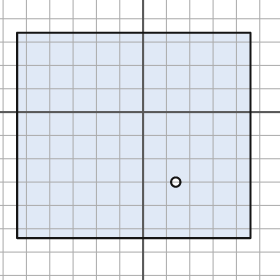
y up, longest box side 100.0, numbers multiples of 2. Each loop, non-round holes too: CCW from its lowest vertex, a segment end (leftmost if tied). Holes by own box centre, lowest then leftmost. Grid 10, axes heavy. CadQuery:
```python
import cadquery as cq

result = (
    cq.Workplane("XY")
    .moveTo(-54.0, -54.0)
    .lineTo(46.0, -54.0)
    .lineTo(46.0, 34.0)
    .lineTo(-54.0, 34.0)
    .close()
    .moveTo(14.0, -30.0)
    .circle(2.0)
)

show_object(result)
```